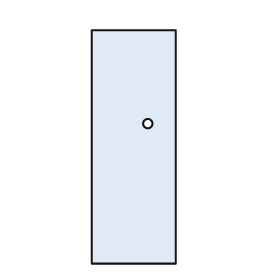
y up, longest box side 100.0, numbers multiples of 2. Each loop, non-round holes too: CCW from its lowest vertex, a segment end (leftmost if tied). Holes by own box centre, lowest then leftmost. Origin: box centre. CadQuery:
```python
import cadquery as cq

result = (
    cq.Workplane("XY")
    .moveTo(-18.0, -50.0)
    .lineTo(18.0, -50.0)
    .lineTo(18.0, 50.0)
    .lineTo(-18.0, 50.0)
    .close()
    .moveTo(6.0, 10.0)
    .circle(2.0)
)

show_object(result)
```